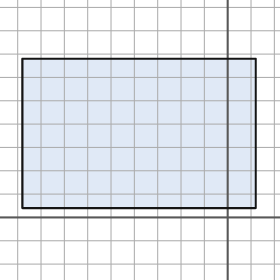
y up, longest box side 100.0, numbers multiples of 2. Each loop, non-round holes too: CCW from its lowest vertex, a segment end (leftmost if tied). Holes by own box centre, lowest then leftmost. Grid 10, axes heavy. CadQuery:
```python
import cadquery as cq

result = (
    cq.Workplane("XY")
    .moveTo(-88.0, 4.0)
    .lineTo(12.0, 4.0)
    .lineTo(12.0, 68.0)
    .lineTo(-88.0, 68.0)
    .close()
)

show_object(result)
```